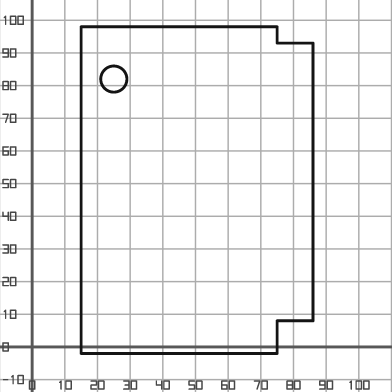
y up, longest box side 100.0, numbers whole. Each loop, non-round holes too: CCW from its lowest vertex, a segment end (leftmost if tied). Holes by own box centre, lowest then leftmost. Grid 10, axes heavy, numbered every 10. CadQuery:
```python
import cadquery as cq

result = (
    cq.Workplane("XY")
    .moveTo(15.0, -2.0)
    .lineTo(75.0, -2.0)
    .lineTo(75.0, 8.0)
    .lineTo(86.0, 8.0)
    .lineTo(86.0, 93.0)
    .lineTo(75.0, 93.0)
    .lineTo(75.0, 98.0)
    .lineTo(15.0, 98.0)
    .close()
    .moveTo(25.0, 82.0)
    .circle(4.0)
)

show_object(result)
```